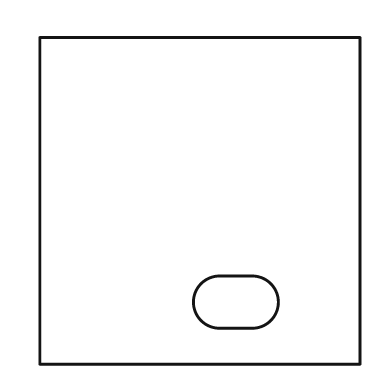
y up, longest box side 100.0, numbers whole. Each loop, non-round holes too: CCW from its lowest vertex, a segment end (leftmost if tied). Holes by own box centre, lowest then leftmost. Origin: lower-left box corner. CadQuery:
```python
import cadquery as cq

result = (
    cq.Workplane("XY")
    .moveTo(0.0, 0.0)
    .lineTo(98.0, 0.0)
    .lineTo(98.0, 100.0)
    .lineTo(0.0, 100.0)
    .close()
    .moveTo(55.0, 11.0)
    .lineTo(65.0, 11.0)
    .threePointArc((73.0, 19.0), (65.0, 27.0))
    .lineTo(55.0, 27.0)
    .threePointArc((47.0, 19.0), (55.0, 11.0))
    .close()
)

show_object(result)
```